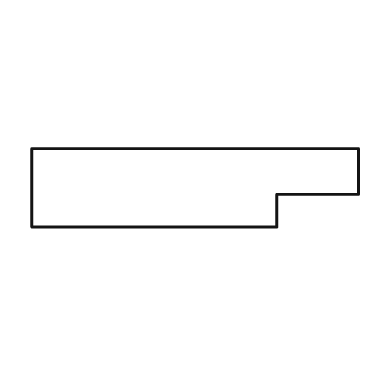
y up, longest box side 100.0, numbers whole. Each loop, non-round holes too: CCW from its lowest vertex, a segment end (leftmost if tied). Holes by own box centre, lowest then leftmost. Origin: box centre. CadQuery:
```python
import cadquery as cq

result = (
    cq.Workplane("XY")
    .moveTo(-50.0, -12.0)
    .lineTo(25.0, -12.0)
    .lineTo(25.0, -2.0)
    .lineTo(50.0, -2.0)
    .lineTo(50.0, 12.0)
    .lineTo(-50.0, 12.0)
    .close()
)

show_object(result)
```